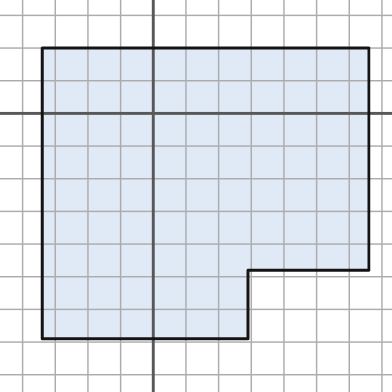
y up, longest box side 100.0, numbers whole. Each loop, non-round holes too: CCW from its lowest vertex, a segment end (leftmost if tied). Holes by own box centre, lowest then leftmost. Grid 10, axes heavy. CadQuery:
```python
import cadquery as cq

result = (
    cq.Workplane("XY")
    .moveTo(-34.0, -69.0)
    .lineTo(29.0, -69.0)
    .lineTo(29.0, -48.0)
    .lineTo(66.0, -48.0)
    .lineTo(66.0, 20.0)
    .lineTo(-34.0, 20.0)
    .close()
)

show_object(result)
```